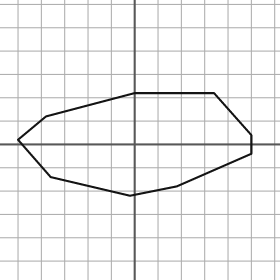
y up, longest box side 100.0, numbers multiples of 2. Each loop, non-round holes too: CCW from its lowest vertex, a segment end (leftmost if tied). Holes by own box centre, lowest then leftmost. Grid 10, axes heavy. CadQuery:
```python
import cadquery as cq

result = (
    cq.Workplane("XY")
    .moveTo(-2.0, -22.0)
    .lineTo(18.0, -18.0)
    .lineTo(50.0, -4.0)
    .lineTo(50.0, 4.0)
    .lineTo(34.0, 22.0)
    .lineTo(0.0, 22.0)
    .lineTo(-38.0, 12.0)
    .lineTo(-50.0, 2.0)
    .lineTo(-36.0, -14.0)
    .close()
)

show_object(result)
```